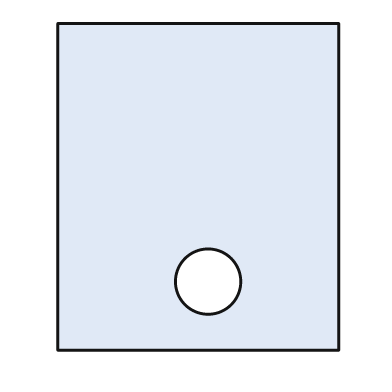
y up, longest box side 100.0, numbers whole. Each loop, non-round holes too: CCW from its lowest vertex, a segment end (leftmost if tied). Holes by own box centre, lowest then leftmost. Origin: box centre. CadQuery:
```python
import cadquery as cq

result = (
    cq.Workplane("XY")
    .moveTo(-43.0, -50.0)
    .lineTo(43.0, -50.0)
    .lineTo(43.0, 50.0)
    .lineTo(-43.0, 50.0)
    .close()
    .moveTo(3.0, -29.0)
    .circle(10.0)
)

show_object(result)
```